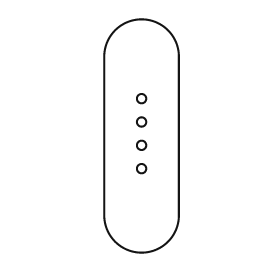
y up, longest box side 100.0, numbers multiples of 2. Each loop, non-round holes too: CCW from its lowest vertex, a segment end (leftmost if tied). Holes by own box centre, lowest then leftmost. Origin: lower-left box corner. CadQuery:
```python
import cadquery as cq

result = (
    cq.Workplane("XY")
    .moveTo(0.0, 16.0)
    .threePointArc((16.0, 0.0), (32.0, 16.0))
    .lineTo(32.0, 84.0)
    .threePointArc((16.0, 100.0), (0.0, 84.0))
    .close()
    .moveTo(16.0, 36.0)
    .circle(2.0)
    .moveTo(16.0, 46.0)
    .circle(2.0)
    .moveTo(16.0, 56.0)
    .circle(2.0)
    .moveTo(16.0, 66.0)
    .circle(2.0)
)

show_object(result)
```